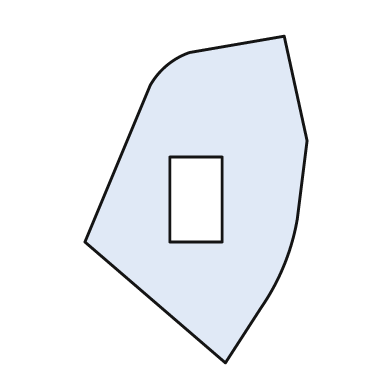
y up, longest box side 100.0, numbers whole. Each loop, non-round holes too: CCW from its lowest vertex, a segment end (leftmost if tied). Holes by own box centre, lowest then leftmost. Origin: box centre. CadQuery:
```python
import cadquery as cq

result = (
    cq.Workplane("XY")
    .moveTo(9.0, -50.0)
    .lineTo(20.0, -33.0)
    .threePointArc((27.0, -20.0), (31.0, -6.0))
    .lineTo(34.0, 18.0)
    .lineTo(27.0, 50.0)
    .lineTo(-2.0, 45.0)
    .threePointArc((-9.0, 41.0), (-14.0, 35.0))
    .lineTo(-34.0, -13.0)
    .close()
    .moveTo(-8.0, -13.0)
    .lineTo(8.0, -13.0)
    .lineTo(8.0, 13.0)
    .lineTo(-8.0, 13.0)
    .close()
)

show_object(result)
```